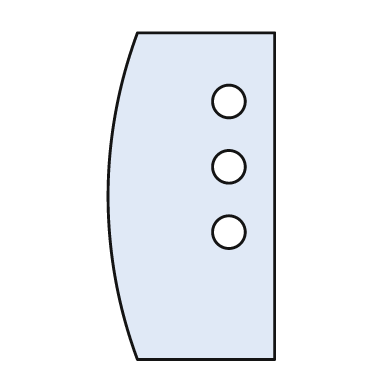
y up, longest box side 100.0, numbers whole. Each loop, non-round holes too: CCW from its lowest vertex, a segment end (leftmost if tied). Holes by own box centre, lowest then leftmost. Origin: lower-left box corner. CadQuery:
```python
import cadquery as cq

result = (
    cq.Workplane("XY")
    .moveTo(9.0, 0.0)
    .lineTo(51.0, 0.0)
    .lineTo(51.0, 100.0)
    .lineTo(9.0, 100.0)
    .threePointArc((0.0, 50.0), (9.0, 0.0))
    .close()
    .moveTo(37.0, 39.0)
    .circle(5.0)
    .moveTo(37.0, 59.0)
    .circle(5.0)
    .moveTo(37.0, 79.0)
    .circle(5.0)
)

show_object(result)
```